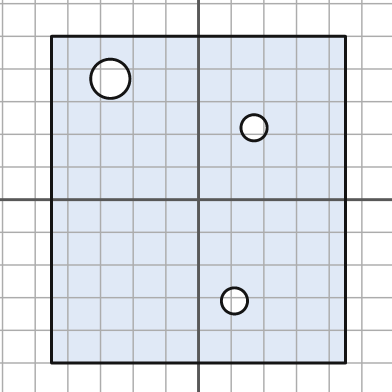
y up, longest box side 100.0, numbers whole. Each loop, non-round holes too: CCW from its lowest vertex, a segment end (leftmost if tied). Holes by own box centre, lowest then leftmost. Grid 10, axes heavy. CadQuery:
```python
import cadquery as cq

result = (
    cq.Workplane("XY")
    .moveTo(-45.0, -50.0)
    .lineTo(45.0, -50.0)
    .lineTo(45.0, 50.0)
    .lineTo(-45.0, 50.0)
    .close()
    .moveTo(11.0, -31.0)
    .circle(4.0)
    .moveTo(17.0, 22.0)
    .circle(4.0)
    .moveTo(-27.0, 37.0)
    .circle(6.0)
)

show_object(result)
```